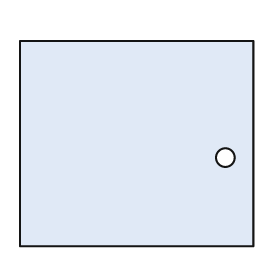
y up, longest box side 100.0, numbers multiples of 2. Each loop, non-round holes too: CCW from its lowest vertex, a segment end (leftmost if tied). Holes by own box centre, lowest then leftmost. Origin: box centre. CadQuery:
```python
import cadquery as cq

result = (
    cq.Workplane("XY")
    .moveTo(-50.0, -44.0)
    .lineTo(50.0, -44.0)
    .lineTo(50.0, 44.0)
    .lineTo(-50.0, 44.0)
    .close()
    .moveTo(38.0, -6.0)
    .circle(4.0)
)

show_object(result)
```